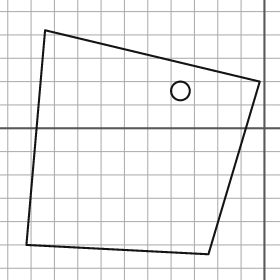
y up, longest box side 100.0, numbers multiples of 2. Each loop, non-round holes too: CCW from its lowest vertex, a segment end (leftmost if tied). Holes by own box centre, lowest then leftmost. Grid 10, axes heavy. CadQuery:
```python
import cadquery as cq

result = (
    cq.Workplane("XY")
    .moveTo(-24.0, -54.0)
    .lineTo(-2.0, 20.0)
    .lineTo(-94.0, 42.0)
    .lineTo(-102.0, -50.0)
    .close()
    .moveTo(-36.0, 16.0)
    .circle(4.0)
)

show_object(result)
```